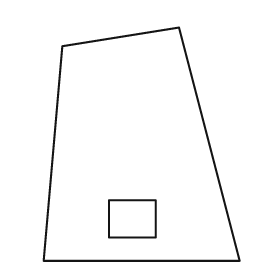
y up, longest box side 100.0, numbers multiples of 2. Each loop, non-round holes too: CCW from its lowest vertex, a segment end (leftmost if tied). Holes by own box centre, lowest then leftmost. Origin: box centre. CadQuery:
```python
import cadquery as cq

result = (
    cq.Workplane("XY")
    .moveTo(-42.0, -50.0)
    .lineTo(42.0, -50.0)
    .lineTo(16.0, 50.0)
    .lineTo(-34.0, 42.0)
    .close()
    .moveTo(-14.0, -40.0)
    .lineTo(6.0, -40.0)
    .lineTo(6.0, -24.0)
    .lineTo(-14.0, -24.0)
    .close()
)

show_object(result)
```